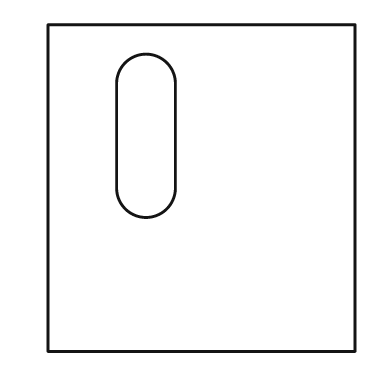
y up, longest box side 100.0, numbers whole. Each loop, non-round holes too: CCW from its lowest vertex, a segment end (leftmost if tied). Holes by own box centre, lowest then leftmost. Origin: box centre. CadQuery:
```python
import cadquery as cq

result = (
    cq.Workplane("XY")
    .moveTo(-47.0, -50.0)
    .lineTo(47.0, -50.0)
    .lineTo(47.0, 50.0)
    .lineTo(-47.0, 50.0)
    .close()
    .moveTo(-26.0, 0.0)
    .threePointArc((-17.0, -9.0), (-8.0, 0.0))
    .lineTo(-8.0, 32.0)
    .threePointArc((-17.0, 41.0), (-26.0, 32.0))
    .close()
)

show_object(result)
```